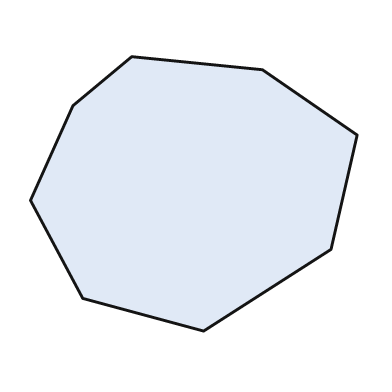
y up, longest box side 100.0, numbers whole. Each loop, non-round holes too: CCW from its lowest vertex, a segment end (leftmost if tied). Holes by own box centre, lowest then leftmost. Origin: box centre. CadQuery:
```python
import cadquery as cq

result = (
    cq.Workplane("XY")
    .moveTo(3.0, -42.0)
    .lineTo(42.0, -17.0)
    .lineTo(50.0, 18.0)
    .lineTo(21.0, 38.0)
    .lineTo(-19.0, 42.0)
    .lineTo(-37.0, 27.0)
    .lineTo(-50.0, -2.0)
    .lineTo(-34.0, -32.0)
    .close()
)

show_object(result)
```